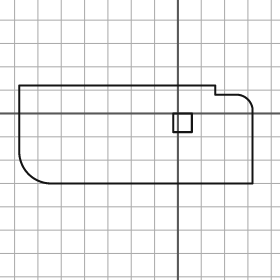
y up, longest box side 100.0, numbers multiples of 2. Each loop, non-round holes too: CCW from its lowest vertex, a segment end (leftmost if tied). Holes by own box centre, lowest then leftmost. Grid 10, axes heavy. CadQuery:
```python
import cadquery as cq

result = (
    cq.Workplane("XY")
    .moveTo(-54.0, -30.0)
    .lineTo(32.0, -30.0)
    .lineTo(32.0, 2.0)
    .threePointArc((30.0, 6.0), (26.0, 8.0))
    .lineTo(16.0, 8.0)
    .lineTo(16.0, 12.0)
    .lineTo(-68.0, 12.0)
    .lineTo(-68.0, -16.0)
    .threePointArc((-64.0, -26.0), (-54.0, -30.0))
    .close()
    .moveTo(-2.0, -8.0)
    .lineTo(6.0, -8.0)
    .lineTo(6.0, 0.0)
    .lineTo(-2.0, 0.0)
    .close()
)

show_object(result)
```